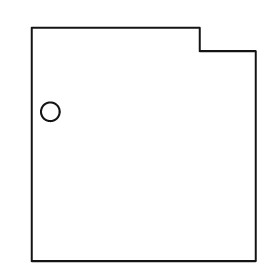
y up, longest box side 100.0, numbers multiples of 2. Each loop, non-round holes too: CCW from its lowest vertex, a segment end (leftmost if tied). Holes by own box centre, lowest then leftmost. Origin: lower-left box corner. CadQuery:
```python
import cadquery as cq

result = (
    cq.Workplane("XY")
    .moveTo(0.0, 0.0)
    .lineTo(96.0, 0.0)
    .lineTo(96.0, 90.0)
    .lineTo(72.0, 90.0)
    .lineTo(72.0, 100.0)
    .lineTo(0.0, 100.0)
    .close()
    .moveTo(8.0, 64.0)
    .circle(4.0)
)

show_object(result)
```